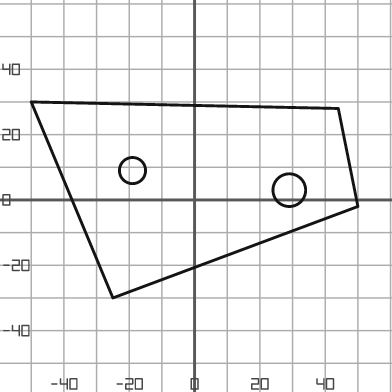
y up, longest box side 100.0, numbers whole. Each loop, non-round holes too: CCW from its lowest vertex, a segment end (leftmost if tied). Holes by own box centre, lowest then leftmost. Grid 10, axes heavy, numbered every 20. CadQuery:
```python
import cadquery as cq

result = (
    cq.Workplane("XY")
    .moveTo(-25.0, -30.0)
    .lineTo(50.0, -2.0)
    .lineTo(44.0, 28.0)
    .lineTo(-50.0, 30.0)
    .close()
    .moveTo(29.0, 3.0)
    .circle(5.0)
    .moveTo(-19.0, 9.0)
    .circle(4.0)
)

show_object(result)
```